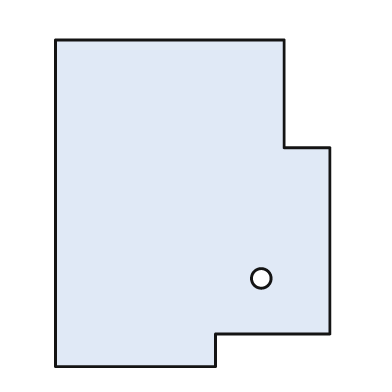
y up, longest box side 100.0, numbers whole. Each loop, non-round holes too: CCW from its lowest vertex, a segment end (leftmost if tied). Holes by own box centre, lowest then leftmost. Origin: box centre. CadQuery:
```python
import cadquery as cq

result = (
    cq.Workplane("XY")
    .moveTo(-42.0, -50.0)
    .lineTo(7.0, -50.0)
    .lineTo(7.0, -40.0)
    .lineTo(42.0, -40.0)
    .lineTo(42.0, 17.0)
    .lineTo(28.0, 17.0)
    .lineTo(28.0, 50.0)
    .lineTo(-42.0, 50.0)
    .close()
    .moveTo(21.0, -23.0)
    .circle(3.0)
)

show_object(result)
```